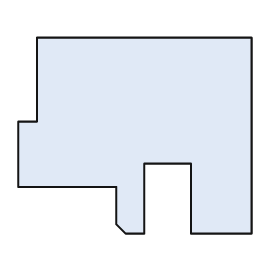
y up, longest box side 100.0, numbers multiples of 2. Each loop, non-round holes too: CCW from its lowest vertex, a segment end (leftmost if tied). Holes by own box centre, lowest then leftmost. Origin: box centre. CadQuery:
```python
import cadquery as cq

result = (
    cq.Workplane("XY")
    .moveTo(-4.0, -42.0)
    .lineTo(4.0, -42.0)
    .lineTo(4.0, -12.0)
    .lineTo(24.0, -12.0)
    .lineTo(24.0, -42.0)
    .lineTo(50.0, -42.0)
    .lineTo(50.0, 42.0)
    .lineTo(-42.0, 42.0)
    .lineTo(-42.0, 6.0)
    .lineTo(-50.0, 6.0)
    .lineTo(-50.0, -22.0)
    .lineTo(-8.0, -22.0)
    .lineTo(-8.0, -38.0)
    .close()
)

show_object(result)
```